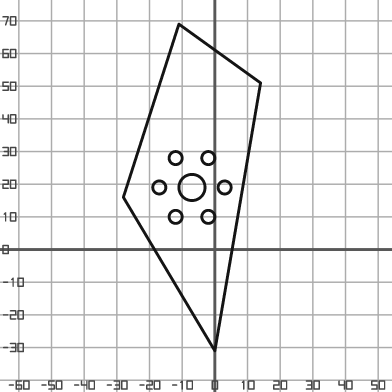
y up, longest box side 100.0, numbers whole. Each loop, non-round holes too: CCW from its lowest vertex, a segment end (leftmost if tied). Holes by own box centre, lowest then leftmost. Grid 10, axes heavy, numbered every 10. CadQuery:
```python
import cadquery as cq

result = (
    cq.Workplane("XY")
    .moveTo(0.0, -31.0)
    .lineTo(14.0, 51.0)
    .lineTo(-11.0, 69.0)
    .lineTo(-28.0, 16.0)
    .close()
    .moveTo(-12.0, 10.0)
    .circle(2.0)
    .moveTo(-2.0, 10.0)
    .circle(2.0)
    .moveTo(-17.0, 19.0)
    .circle(2.0)
    .moveTo(-7.0, 19.0)
    .circle(4.0)
    .moveTo(3.0, 19.0)
    .circle(2.0)
    .moveTo(-12.0, 28.0)
    .circle(2.0)
    .moveTo(-2.0, 28.0)
    .circle(2.0)
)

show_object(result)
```